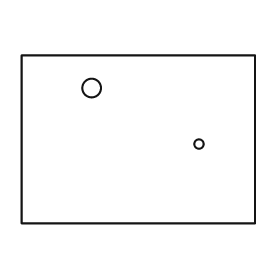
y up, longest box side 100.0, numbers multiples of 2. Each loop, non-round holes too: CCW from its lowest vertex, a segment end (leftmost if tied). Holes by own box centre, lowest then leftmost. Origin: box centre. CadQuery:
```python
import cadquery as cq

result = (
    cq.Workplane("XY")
    .moveTo(-50.0, -36.0)
    .lineTo(50.0, -36.0)
    .lineTo(50.0, 36.0)
    .lineTo(-50.0, 36.0)
    .close()
    .moveTo(26.0, -2.0)
    .circle(2.0)
    .moveTo(-20.0, 22.0)
    .circle(4.0)
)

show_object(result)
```